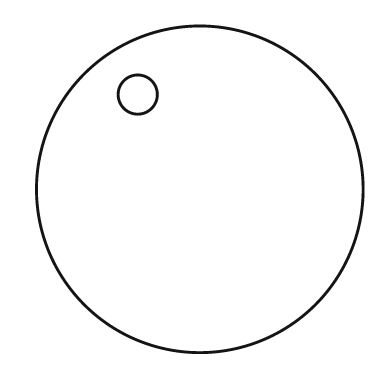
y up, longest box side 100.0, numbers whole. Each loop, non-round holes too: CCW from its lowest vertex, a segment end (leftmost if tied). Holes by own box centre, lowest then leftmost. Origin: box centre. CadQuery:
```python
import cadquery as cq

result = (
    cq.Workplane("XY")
    .moveTo(0.0, 0.0)
    .circle(50.0)
    .moveTo(-19.0, 29.0)
    .circle(6.0)
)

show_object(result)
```